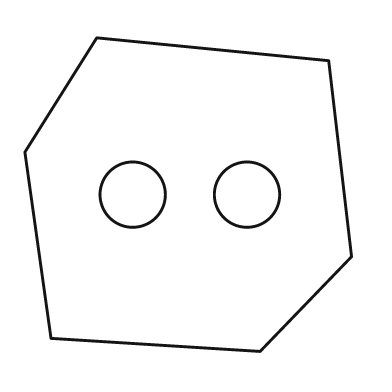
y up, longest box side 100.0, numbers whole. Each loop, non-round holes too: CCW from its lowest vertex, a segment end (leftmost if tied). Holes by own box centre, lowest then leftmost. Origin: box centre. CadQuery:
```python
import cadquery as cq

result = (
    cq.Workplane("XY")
    .moveTo(22.0, -48.0)
    .lineTo(50.0, -19.0)
    .lineTo(43.0, 41.0)
    .lineTo(-28.0, 48.0)
    .lineTo(-50.0, 13.0)
    .lineTo(-42.0, -44.0)
    .close()
    .moveTo(-17.0, 0.0)
    .circle(10.0)
    .moveTo(18.0, 0.0)
    .circle(10.0)
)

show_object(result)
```